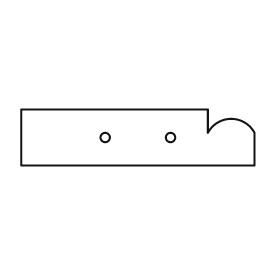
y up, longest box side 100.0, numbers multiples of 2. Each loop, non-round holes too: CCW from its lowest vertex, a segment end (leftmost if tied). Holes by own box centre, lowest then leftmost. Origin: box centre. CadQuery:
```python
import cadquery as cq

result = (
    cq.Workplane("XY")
    .moveTo(-50.0, -12.0)
    .lineTo(50.0, -12.0)
    .lineTo(50.0, 2.0)
    .threePointArc((40.0, 8.0), (30.0, 2.0))
    .lineTo(30.0, 12.0)
    .lineTo(-50.0, 12.0)
    .close()
    .moveTo(-14.0, 0.0)
    .circle(2.0)
    .moveTo(14.0, 0.0)
    .circle(2.0)
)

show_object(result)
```